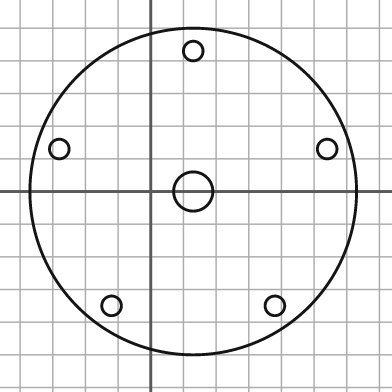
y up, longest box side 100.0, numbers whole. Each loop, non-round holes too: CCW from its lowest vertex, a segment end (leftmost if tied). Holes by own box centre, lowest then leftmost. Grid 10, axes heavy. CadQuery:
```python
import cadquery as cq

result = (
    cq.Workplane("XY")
    .moveTo(13.0, 0.0)
    .circle(50.0)
    .moveTo(-12.0, -35.0)
    .circle(3.0)
    .moveTo(38.0, -35.0)
    .circle(3.0)
    .moveTo(13.0, 0.0)
    .circle(6.0)
    .moveTo(-28.0, 13.0)
    .circle(3.0)
    .moveTo(54.0, 13.0)
    .circle(3.0)
    .moveTo(13.0, 43.0)
    .circle(3.0)
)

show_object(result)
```